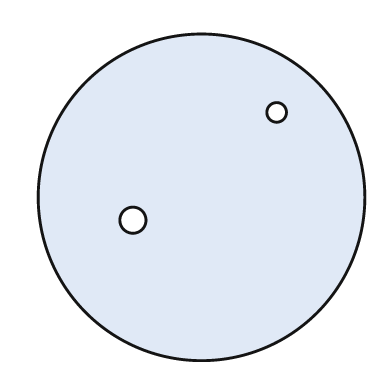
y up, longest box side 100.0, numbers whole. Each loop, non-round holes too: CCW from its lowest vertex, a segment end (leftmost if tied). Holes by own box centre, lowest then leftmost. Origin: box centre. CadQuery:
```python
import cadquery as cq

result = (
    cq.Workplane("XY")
    .moveTo(0.0, 0.0)
    .circle(50.0)
    .moveTo(-21.0, -7.0)
    .circle(4.0)
    .moveTo(23.0, 26.0)
    .circle(3.0)
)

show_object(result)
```